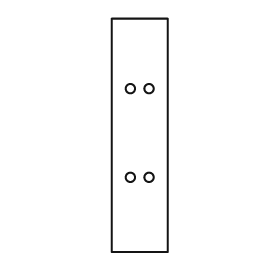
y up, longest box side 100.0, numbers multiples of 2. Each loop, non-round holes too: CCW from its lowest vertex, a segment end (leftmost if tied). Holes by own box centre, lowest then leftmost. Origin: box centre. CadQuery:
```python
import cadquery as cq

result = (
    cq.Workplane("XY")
    .moveTo(-12.0, -50.0)
    .lineTo(12.0, -50.0)
    .lineTo(12.0, 50.0)
    .lineTo(-12.0, 50.0)
    .close()
    .moveTo(-4.0, -18.0)
    .circle(2.0)
    .moveTo(4.0, -18.0)
    .circle(2.0)
    .moveTo(-4.0, 20.0)
    .circle(2.0)
    .moveTo(4.0, 20.0)
    .circle(2.0)
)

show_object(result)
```